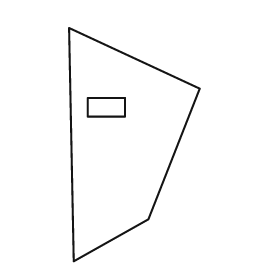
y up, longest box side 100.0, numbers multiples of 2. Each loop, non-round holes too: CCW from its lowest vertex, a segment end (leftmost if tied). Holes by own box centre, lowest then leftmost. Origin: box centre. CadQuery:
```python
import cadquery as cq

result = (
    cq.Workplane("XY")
    .moveTo(-26.0, -50.0)
    .lineTo(6.0, -32.0)
    .lineTo(28.0, 24.0)
    .lineTo(-28.0, 50.0)
    .close()
    .moveTo(-20.0, 12.0)
    .lineTo(-4.0, 12.0)
    .lineTo(-4.0, 20.0)
    .lineTo(-20.0, 20.0)
    .close()
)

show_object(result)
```